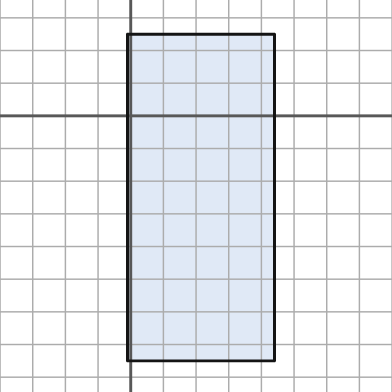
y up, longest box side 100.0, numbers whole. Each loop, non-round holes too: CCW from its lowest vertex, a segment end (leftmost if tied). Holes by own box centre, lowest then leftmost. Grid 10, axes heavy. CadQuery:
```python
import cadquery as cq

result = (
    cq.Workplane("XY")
    .moveTo(-1.0, -75.0)
    .lineTo(44.0, -75.0)
    .lineTo(44.0, 25.0)
    .lineTo(-1.0, 25.0)
    .close()
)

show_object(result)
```